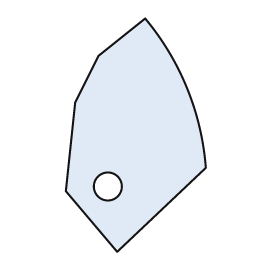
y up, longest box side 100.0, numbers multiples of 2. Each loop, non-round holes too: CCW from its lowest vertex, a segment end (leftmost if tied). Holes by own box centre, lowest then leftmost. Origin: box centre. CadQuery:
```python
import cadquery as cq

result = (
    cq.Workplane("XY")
    .moveTo(-8.0, -50.0)
    .lineTo(30.0, -14.0)
    .threePointArc((22.0, 20.0), (4.0, 50.0))
    .lineTo(-16.0, 34.0)
    .lineTo(-26.0, 14.0)
    .lineTo(-30.0, -24.0)
    .close()
    .moveTo(-12.0, -22.0)
    .circle(6.0)
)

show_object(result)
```